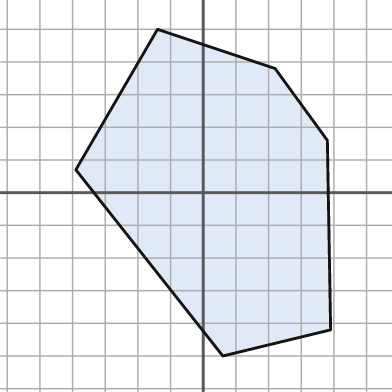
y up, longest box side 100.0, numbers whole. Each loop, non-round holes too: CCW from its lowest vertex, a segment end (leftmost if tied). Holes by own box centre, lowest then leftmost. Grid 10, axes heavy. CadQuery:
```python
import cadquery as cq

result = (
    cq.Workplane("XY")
    .moveTo(6.0, -50.0)
    .lineTo(39.0, -42.0)
    .lineTo(38.0, 16.0)
    .lineTo(22.0, 38.0)
    .lineTo(-14.0, 50.0)
    .lineTo(-39.0, 7.0)
    .close()
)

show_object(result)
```